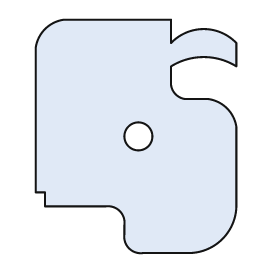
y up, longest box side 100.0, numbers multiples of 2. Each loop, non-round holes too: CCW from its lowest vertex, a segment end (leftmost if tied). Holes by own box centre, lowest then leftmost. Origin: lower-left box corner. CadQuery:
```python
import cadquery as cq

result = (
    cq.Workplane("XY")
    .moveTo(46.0, 0.0)
    .lineTo(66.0, 0.0)
    .threePointArc((80.0, 6.0), (86.0, 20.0))
    .lineTo(86.0, 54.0)
    .threePointArc((82.0, 62.0), (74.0, 66.0))
    .lineTo(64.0, 66.0)
    .threePointArc((60.0, 68.0), (58.0, 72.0))
    .lineTo(58.0, 80.0)
    .threePointArc((72.0, 84.0), (86.0, 80.0))
    .lineTo(86.0, 90.0)
    .threePointArc((72.0, 96.0), (58.0, 90.0))
    .lineTo(58.0, 100.0)
    .lineTo(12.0, 100.0)
    .threePointArc((4.0, 96.0), (0.0, 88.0))
    .lineTo(0.0, 26.0)
    .lineTo(4.0, 26.0)
    .lineTo(4.0, 20.0)
    .lineTo(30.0, 20.0)
    .threePointArc((36.0, 18.0), (38.0, 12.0))
    .lineTo(38.0, 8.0)
    .threePointArc((40.0, 2.0), (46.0, 0.0))
    .close()
    .moveTo(44.0, 50.0)
    .circle(6.0)
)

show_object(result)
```